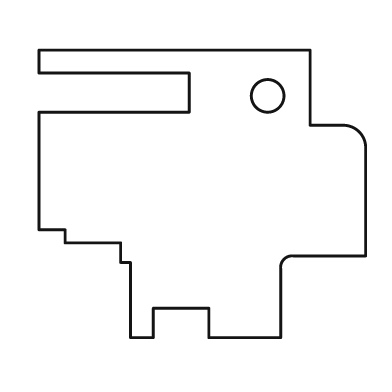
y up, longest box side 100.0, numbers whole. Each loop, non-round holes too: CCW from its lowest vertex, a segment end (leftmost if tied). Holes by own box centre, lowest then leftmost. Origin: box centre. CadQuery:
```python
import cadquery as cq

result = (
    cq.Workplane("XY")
    .moveTo(-22.0, -44.0)
    .lineTo(-15.0, -44.0)
    .lineTo(-15.0, -35.0)
    .lineTo(2.0, -35.0)
    .lineTo(2.0, -44.0)
    .lineTo(24.0, -44.0)
    .lineTo(24.0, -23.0)
    .threePointArc((25.0, -20.0), (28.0, -19.0))
    .lineTo(50.0, -19.0)
    .lineTo(50.0, 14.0)
    .threePointArc((48.0, 19.0), (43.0, 21.0))
    .lineTo(33.0, 21.0)
    .lineTo(33.0, 44.0)
    .lineTo(-50.0, 44.0)
    .lineTo(-50.0, 37.0)
    .lineTo(-4.0, 37.0)
    .lineTo(-4.0, 25.0)
    .lineTo(-50.0, 25.0)
    .lineTo(-50.0, -11.0)
    .lineTo(-42.0, -11.0)
    .lineTo(-42.0, -15.0)
    .lineTo(-25.0, -15.0)
    .lineTo(-25.0, -21.0)
    .lineTo(-22.0, -21.0)
    .close()
    .moveTo(20.0, 30.0)
    .circle(5.0)
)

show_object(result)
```